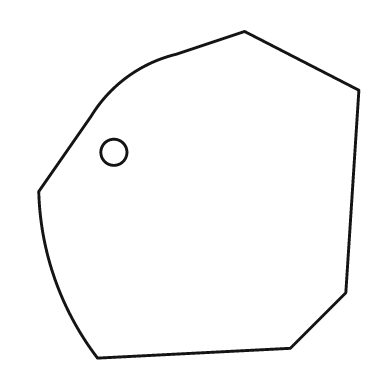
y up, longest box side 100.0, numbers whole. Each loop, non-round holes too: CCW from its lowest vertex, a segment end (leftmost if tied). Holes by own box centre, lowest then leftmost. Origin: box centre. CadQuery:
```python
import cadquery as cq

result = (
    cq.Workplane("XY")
    .moveTo(-31.0, -50.0)
    .lineTo(28.0, -47.0)
    .lineTo(45.0, -30.0)
    .lineTo(49.0, 32.0)
    .lineTo(14.0, 50.0)
    .lineTo(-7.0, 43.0)
    .threePointArc((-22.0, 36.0), (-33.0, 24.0))
    .lineTo(-49.0, 1.0)
    .threePointArc((-44.0, -26.0), (-31.0, -50.0))
    .close()
    .moveTo(-26.0, 13.0)
    .circle(4.0)
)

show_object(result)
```